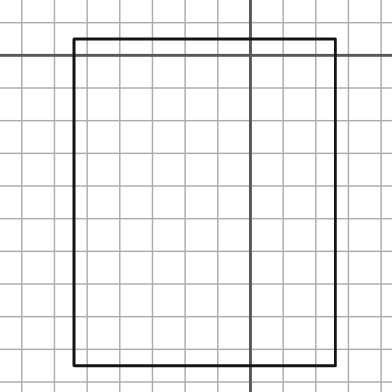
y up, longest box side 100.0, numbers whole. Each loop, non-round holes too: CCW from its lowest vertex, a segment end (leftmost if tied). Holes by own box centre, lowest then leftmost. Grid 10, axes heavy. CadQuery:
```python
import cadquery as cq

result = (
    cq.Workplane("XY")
    .moveTo(-54.0, -95.0)
    .lineTo(26.0, -95.0)
    .lineTo(26.0, 5.0)
    .lineTo(-54.0, 5.0)
    .close()
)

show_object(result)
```